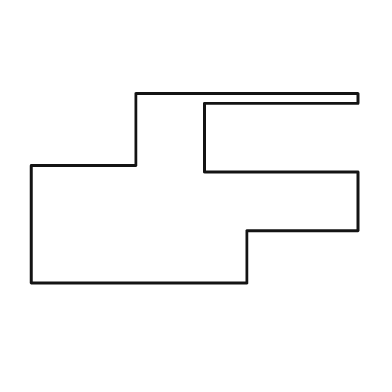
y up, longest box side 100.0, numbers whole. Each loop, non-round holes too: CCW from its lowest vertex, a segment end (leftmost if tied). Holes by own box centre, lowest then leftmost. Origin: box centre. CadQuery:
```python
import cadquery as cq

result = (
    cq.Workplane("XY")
    .moveTo(-50.0, -29.0)
    .lineTo(16.0, -29.0)
    .lineTo(16.0, -13.0)
    .lineTo(50.0, -13.0)
    .lineTo(50.0, 5.0)
    .lineTo(3.0, 5.0)
    .lineTo(3.0, 26.0)
    .lineTo(50.0, 26.0)
    .lineTo(50.0, 29.0)
    .lineTo(-18.0, 29.0)
    .lineTo(-18.0, 7.0)
    .lineTo(-50.0, 7.0)
    .close()
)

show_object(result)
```